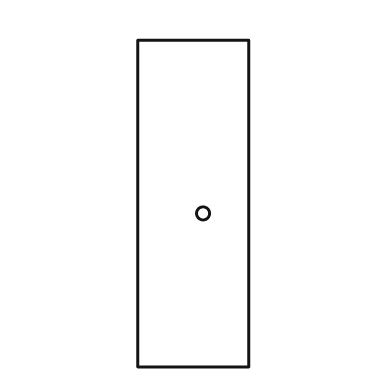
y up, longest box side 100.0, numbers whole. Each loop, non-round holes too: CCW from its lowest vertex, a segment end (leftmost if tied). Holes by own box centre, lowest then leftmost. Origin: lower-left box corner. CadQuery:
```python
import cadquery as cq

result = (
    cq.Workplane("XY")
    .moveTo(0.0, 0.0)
    .lineTo(34.0, 0.0)
    .lineTo(34.0, 100.0)
    .lineTo(0.0, 100.0)
    .close()
    .moveTo(20.0, 47.0)
    .circle(2.0)
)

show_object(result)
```